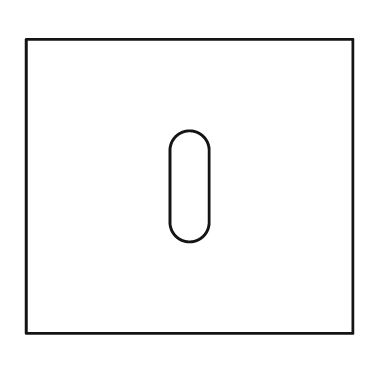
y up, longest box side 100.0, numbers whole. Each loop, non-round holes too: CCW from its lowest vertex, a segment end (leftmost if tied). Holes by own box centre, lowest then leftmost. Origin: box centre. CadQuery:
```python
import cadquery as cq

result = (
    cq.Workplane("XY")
    .moveTo(-50.0, -45.0)
    .lineTo(50.0, -45.0)
    .lineTo(50.0, 45.0)
    .lineTo(-50.0, 45.0)
    .close()
    .moveTo(-6.0, -11.0)
    .threePointArc((0.0, -17.0), (6.0, -11.0))
    .lineTo(6.0, 11.0)
    .threePointArc((0.0, 17.0), (-6.0, 11.0))
    .close()
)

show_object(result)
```